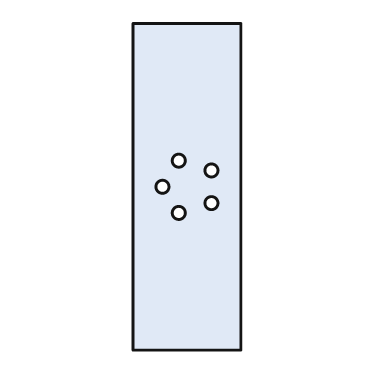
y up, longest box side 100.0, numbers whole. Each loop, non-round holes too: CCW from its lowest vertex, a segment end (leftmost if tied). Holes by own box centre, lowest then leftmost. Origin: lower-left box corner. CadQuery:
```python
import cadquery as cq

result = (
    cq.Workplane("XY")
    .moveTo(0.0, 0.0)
    .lineTo(33.0, 0.0)
    .lineTo(33.0, 100.0)
    .lineTo(0.0, 100.0)
    .close()
    .moveTo(14.0, 42.0)
    .circle(2.0)
    .moveTo(24.0, 45.0)
    .circle(2.0)
    .moveTo(9.0, 50.0)
    .circle(2.0)
    .moveTo(24.0, 55.0)
    .circle(2.0)
    .moveTo(14.0, 58.0)
    .circle(2.0)
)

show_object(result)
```